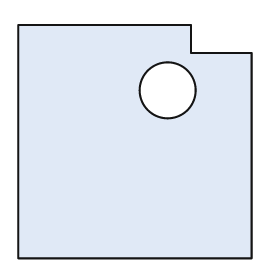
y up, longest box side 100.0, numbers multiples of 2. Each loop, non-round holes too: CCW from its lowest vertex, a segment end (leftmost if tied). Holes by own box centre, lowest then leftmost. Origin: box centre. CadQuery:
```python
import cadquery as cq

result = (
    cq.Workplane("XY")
    .moveTo(-50.0, -50.0)
    .lineTo(50.0, -50.0)
    .lineTo(50.0, 38.0)
    .lineTo(24.0, 38.0)
    .lineTo(24.0, 50.0)
    .lineTo(-50.0, 50.0)
    .close()
    .moveTo(14.0, 22.0)
    .circle(12.0)
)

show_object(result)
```